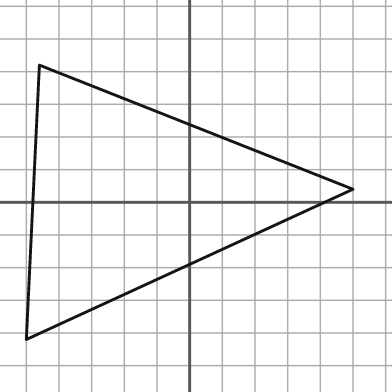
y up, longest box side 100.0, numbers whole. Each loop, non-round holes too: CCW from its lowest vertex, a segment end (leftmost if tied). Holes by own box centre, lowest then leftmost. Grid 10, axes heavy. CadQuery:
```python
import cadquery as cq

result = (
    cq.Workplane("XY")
    .moveTo(-50.0, -42.0)
    .lineTo(50.0, 4.0)
    .lineTo(-46.0, 42.0)
    .close()
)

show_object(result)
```